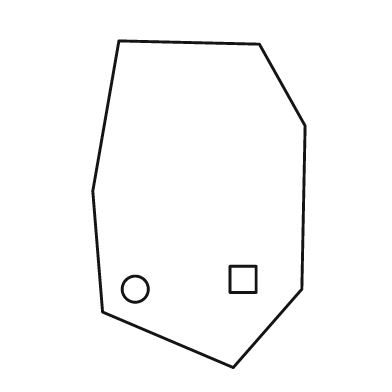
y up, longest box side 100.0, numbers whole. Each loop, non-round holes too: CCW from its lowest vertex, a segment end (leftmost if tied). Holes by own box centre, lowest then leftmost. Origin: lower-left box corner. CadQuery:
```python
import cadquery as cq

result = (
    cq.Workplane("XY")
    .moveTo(43.0, 0.0)
    .lineTo(64.0, 24.0)
    .lineTo(65.0, 74.0)
    .lineTo(51.0, 99.0)
    .lineTo(8.0, 100.0)
    .lineTo(0.0, 54.0)
    .lineTo(3.0, 17.0)
    .close()
    .moveTo(13.0, 24.0)
    .circle(4.0)
    .moveTo(42.0, 23.0)
    .lineTo(50.0, 23.0)
    .lineTo(50.0, 31.0)
    .lineTo(42.0, 31.0)
    .close()
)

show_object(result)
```